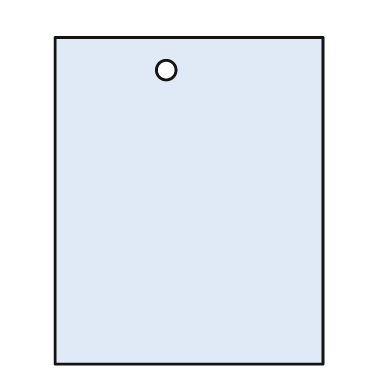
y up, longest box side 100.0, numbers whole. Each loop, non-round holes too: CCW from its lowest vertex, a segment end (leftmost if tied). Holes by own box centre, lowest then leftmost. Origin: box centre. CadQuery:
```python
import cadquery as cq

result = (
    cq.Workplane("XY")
    .moveTo(-41.0, -50.0)
    .lineTo(41.0, -50.0)
    .lineTo(41.0, 50.0)
    .lineTo(-41.0, 50.0)
    .close()
    .moveTo(-7.0, 40.0)
    .circle(3.0)
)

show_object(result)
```